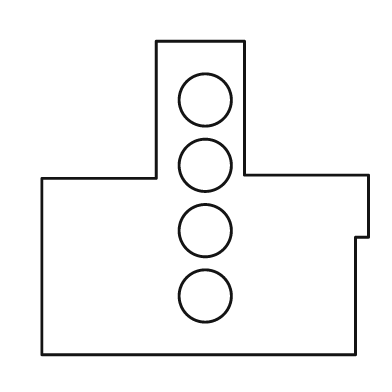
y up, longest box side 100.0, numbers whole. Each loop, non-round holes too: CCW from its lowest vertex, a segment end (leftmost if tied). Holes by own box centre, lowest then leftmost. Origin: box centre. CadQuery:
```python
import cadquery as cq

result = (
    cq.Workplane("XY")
    .moveTo(-50.0, -48.0)
    .lineTo(46.0, -48.0)
    .lineTo(46.0, -12.0)
    .lineTo(50.0, -12.0)
    .lineTo(50.0, 7.0)
    .lineTo(12.0, 7.0)
    .lineTo(12.0, 48.0)
    .lineTo(-15.0, 48.0)
    .lineTo(-15.0, 6.0)
    .lineTo(-50.0, 6.0)
    .close()
    .moveTo(0.0, -30.0)
    .circle(8.0)
    .moveTo(0.0, -10.0)
    .circle(8.0)
    .moveTo(0.0, 10.0)
    .circle(8.0)
    .moveTo(0.0, 30.0)
    .circle(8.0)
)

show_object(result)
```